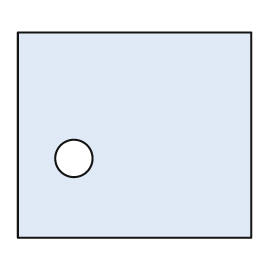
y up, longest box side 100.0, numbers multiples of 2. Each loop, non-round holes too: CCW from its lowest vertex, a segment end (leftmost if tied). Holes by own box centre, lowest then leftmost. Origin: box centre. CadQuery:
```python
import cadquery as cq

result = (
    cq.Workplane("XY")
    .moveTo(-50.0, -44.0)
    .lineTo(50.0, -44.0)
    .lineTo(50.0, 44.0)
    .lineTo(-50.0, 44.0)
    .close()
    .moveTo(-26.0, -10.0)
    .circle(8.0)
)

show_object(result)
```